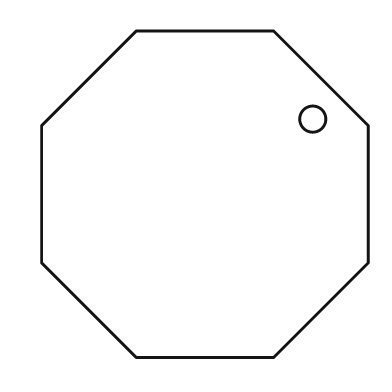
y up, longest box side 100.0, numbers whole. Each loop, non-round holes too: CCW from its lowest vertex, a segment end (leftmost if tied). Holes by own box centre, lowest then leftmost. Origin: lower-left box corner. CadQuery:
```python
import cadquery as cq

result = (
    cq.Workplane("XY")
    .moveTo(29.0, 0.0)
    .lineTo(71.0, 0.0)
    .lineTo(100.0, 29.0)
    .lineTo(100.0, 71.0)
    .lineTo(71.0, 100.0)
    .lineTo(29.0, 100.0)
    .lineTo(0.0, 71.0)
    .lineTo(0.0, 29.0)
    .close()
    .moveTo(83.0, 73.0)
    .circle(4.0)
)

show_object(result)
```